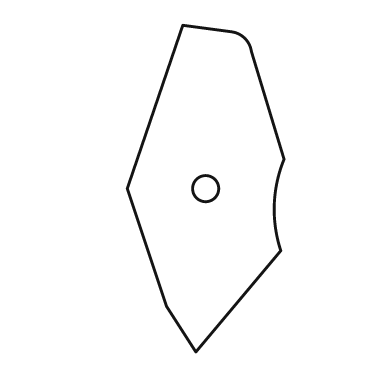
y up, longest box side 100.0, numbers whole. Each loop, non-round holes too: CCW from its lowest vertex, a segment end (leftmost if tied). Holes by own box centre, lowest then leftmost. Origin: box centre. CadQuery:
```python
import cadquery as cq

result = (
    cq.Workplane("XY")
    .moveTo(-3.0, -50.0)
    .lineTo(23.0, -19.0)
    .threePointArc((21.0, -5.0), (24.0, 9.0))
    .lineTo(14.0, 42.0)
    .threePointArc((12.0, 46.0), (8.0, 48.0))
    .lineTo(-7.0, 50.0)
    .lineTo(-24.0, 0.0)
    .lineTo(-12.0, -36.0)
    .close()
    .moveTo(0.0, 0.0)
    .circle(4.0)
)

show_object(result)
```